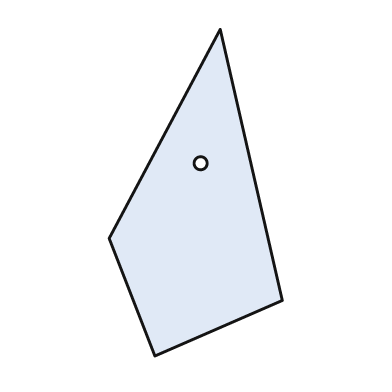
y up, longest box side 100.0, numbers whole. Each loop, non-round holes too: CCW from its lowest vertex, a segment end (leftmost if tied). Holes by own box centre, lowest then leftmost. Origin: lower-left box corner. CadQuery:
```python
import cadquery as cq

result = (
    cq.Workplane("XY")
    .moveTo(14.0, 0.0)
    .lineTo(53.0, 17.0)
    .lineTo(34.0, 100.0)
    .lineTo(0.0, 36.0)
    .close()
    .moveTo(28.0, 59.0)
    .circle(2.0)
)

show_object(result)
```